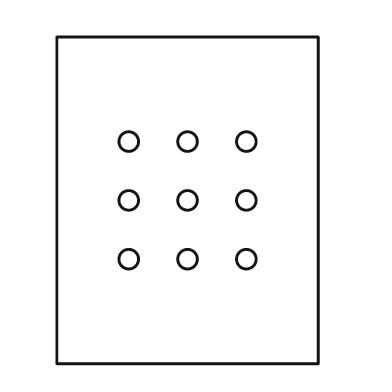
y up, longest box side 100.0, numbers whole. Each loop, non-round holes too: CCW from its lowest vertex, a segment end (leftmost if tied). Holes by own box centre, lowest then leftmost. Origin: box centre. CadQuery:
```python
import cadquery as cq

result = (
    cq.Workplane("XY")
    .moveTo(-40.0, -50.0)
    .lineTo(40.0, -50.0)
    .lineTo(40.0, 50.0)
    .lineTo(-40.0, 50.0)
    .close()
    .moveTo(-18.0, -18.0)
    .circle(3.0)
    .moveTo(0.0, -18.0)
    .circle(3.0)
    .moveTo(18.0, -18.0)
    .circle(3.0)
    .moveTo(-18.0, 0.0)
    .circle(3.0)
    .moveTo(0.0, 0.0)
    .circle(3.0)
    .moveTo(18.0, 0.0)
    .circle(3.0)
    .moveTo(-18.0, 18.0)
    .circle(3.0)
    .moveTo(0.0, 18.0)
    .circle(3.0)
    .moveTo(18.0, 18.0)
    .circle(3.0)
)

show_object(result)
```